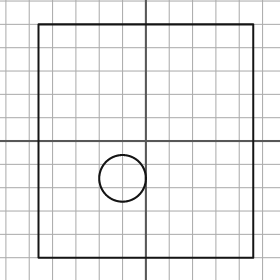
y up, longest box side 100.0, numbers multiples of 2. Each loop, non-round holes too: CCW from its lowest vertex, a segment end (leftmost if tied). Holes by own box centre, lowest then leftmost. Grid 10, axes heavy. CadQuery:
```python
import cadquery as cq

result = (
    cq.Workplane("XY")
    .moveTo(-46.0, -50.0)
    .lineTo(46.0, -50.0)
    .lineTo(46.0, 50.0)
    .lineTo(-46.0, 50.0)
    .close()
    .moveTo(-10.0, -16.0)
    .circle(10.0)
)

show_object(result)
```